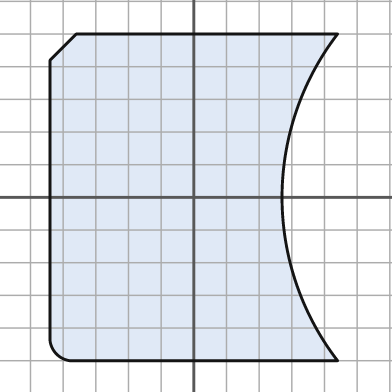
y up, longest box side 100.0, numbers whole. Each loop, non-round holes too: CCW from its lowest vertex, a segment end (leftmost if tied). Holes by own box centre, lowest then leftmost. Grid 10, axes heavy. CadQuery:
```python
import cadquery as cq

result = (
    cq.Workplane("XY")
    .moveTo(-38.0, -50.0)
    .lineTo(44.0, -50.0)
    .threePointArc((27.0, 0.0), (44.0, 50.0))
    .lineTo(-36.0, 50.0)
    .lineTo(-44.0, 42.0)
    .lineTo(-44.0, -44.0)
    .threePointArc((-42.0, -48.0), (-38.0, -50.0))
    .close()
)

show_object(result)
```